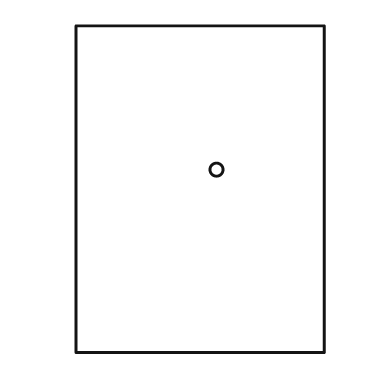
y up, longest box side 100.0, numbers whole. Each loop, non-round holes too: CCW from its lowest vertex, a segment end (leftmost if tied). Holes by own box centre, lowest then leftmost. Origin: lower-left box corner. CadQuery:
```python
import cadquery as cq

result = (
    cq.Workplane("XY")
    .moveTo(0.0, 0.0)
    .lineTo(76.0, 0.0)
    .lineTo(76.0, 100.0)
    .lineTo(0.0, 100.0)
    .close()
    .moveTo(43.0, 56.0)
    .circle(2.0)
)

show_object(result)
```